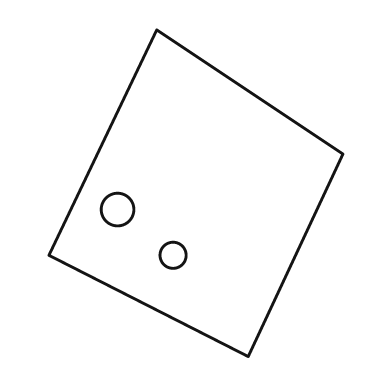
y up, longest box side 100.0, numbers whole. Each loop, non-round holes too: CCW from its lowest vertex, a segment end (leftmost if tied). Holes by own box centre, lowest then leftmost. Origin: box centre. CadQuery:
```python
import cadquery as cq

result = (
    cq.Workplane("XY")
    .moveTo(16.0, -50.0)
    .lineTo(45.0, 12.0)
    .lineTo(-12.0, 50.0)
    .lineTo(-45.0, -19.0)
    .close()
    .moveTo(-7.0, -19.0)
    .circle(4.0)
    .moveTo(-24.0, -5.0)
    .circle(5.0)
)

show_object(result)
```